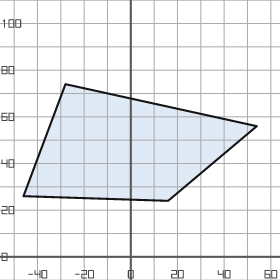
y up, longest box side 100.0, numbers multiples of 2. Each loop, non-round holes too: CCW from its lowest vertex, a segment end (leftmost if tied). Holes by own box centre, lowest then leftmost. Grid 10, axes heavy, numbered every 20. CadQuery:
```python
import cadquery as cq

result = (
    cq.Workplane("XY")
    .moveTo(16.0, 24.0)
    .lineTo(54.0, 56.0)
    .lineTo(-28.0, 74.0)
    .lineTo(-46.0, 26.0)
    .close()
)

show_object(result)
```